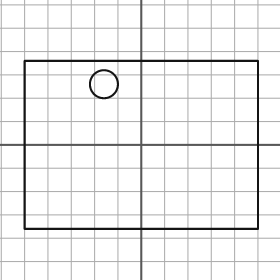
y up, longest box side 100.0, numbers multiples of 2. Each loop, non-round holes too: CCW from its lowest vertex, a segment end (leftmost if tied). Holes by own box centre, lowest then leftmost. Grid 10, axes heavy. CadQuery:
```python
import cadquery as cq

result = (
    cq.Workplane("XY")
    .moveTo(-50.0, -36.0)
    .lineTo(50.0, -36.0)
    .lineTo(50.0, 36.0)
    .lineTo(-50.0, 36.0)
    .close()
    .moveTo(-16.0, 26.0)
    .circle(6.0)
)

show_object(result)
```